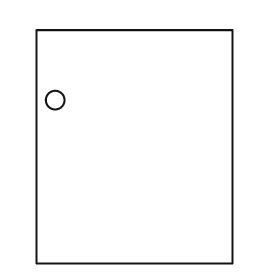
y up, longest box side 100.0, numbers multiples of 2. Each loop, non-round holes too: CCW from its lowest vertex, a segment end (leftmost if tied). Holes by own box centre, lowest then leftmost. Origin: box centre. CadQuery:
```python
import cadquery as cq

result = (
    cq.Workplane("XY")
    .moveTo(-42.0, -50.0)
    .lineTo(42.0, -50.0)
    .lineTo(42.0, 50.0)
    .lineTo(-42.0, 50.0)
    .close()
    .moveTo(-34.0, 20.0)
    .circle(4.0)
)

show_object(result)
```